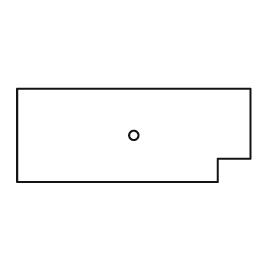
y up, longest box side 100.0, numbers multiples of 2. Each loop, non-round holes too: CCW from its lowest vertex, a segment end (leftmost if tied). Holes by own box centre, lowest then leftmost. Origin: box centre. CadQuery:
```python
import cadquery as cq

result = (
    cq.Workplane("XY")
    .moveTo(-50.0, -20.0)
    .lineTo(36.0, -20.0)
    .lineTo(36.0, -10.0)
    .lineTo(50.0, -10.0)
    .lineTo(50.0, 20.0)
    .lineTo(-50.0, 20.0)
    .close()
    .moveTo(0.0, 0.0)
    .circle(2.0)
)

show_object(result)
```